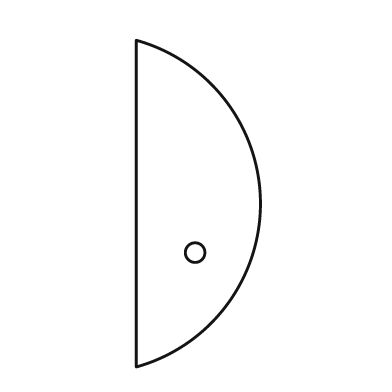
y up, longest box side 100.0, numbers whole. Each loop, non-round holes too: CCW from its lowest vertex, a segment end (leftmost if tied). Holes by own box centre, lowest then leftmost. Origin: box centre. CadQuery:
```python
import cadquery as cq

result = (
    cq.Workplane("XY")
    .moveTo(-19.0, -50.0)
    .threePointArc((19.0, 0.0), (-19.0, 50.0))
    .close()
    .moveTo(-1.0, -15.0)
    .circle(3.0)
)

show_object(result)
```